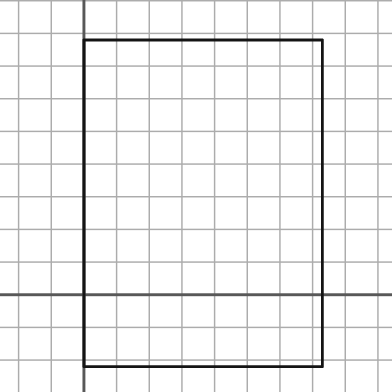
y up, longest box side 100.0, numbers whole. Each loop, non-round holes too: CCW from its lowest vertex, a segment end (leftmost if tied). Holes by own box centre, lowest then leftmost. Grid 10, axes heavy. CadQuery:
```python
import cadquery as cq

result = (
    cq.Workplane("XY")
    .moveTo(0.0, -22.0)
    .lineTo(73.0, -22.0)
    .lineTo(73.0, 78.0)
    .lineTo(0.0, 78.0)
    .close()
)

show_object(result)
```